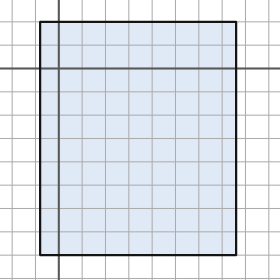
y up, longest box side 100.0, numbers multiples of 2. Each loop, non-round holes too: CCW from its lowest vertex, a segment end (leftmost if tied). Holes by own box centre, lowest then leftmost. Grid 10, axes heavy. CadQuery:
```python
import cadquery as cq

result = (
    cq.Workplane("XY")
    .moveTo(-8.0, -80.0)
    .lineTo(76.0, -80.0)
    .lineTo(76.0, 20.0)
    .lineTo(-8.0, 20.0)
    .close()
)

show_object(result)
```